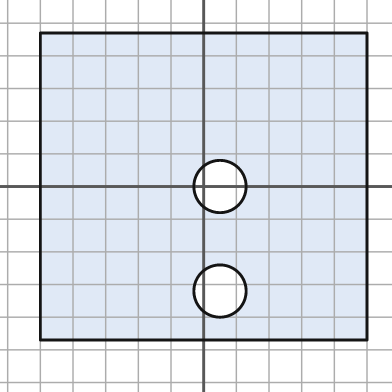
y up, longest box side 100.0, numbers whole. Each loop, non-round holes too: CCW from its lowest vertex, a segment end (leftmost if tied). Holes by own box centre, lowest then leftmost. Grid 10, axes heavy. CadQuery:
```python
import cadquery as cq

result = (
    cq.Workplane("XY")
    .moveTo(-50.0, -47.0)
    .lineTo(50.0, -47.0)
    .lineTo(50.0, 47.0)
    .lineTo(-50.0, 47.0)
    .close()
    .moveTo(5.0, -32.0)
    .circle(8.0)
    .moveTo(5.0, 0.0)
    .circle(8.0)
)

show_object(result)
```